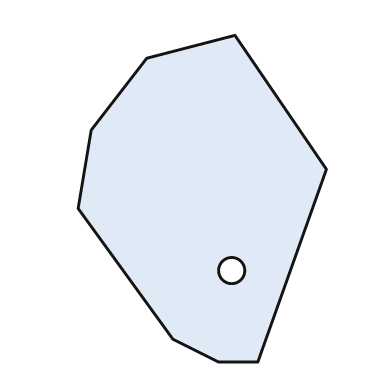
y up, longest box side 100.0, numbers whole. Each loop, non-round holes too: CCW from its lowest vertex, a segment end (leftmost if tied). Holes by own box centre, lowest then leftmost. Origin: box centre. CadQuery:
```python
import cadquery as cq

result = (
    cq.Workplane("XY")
    .moveTo(5.0, -50.0)
    .lineTo(17.0, -50.0)
    .lineTo(38.0, 9.0)
    .lineTo(10.0, 50.0)
    .lineTo(-17.0, 43.0)
    .lineTo(-34.0, 21.0)
    .lineTo(-38.0, -3.0)
    .lineTo(-9.0, -43.0)
    .close()
    .moveTo(9.0, -22.0)
    .circle(4.0)
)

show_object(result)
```